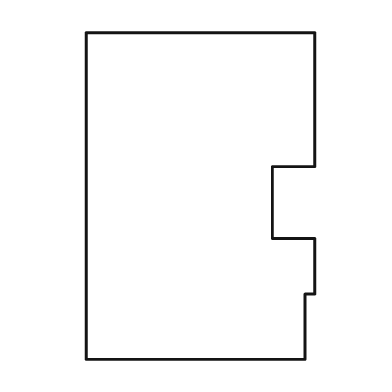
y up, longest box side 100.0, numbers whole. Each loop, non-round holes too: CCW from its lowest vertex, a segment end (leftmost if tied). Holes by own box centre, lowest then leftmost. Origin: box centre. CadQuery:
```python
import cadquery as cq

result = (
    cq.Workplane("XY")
    .moveTo(-35.0, -50.0)
    .lineTo(32.0, -50.0)
    .lineTo(32.0, -30.0)
    .lineTo(35.0, -30.0)
    .lineTo(35.0, -13.0)
    .lineTo(22.0, -13.0)
    .lineTo(22.0, 9.0)
    .lineTo(35.0, 9.0)
    .lineTo(35.0, 50.0)
    .lineTo(-35.0, 50.0)
    .close()
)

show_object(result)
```